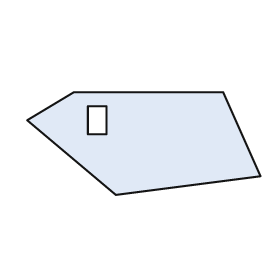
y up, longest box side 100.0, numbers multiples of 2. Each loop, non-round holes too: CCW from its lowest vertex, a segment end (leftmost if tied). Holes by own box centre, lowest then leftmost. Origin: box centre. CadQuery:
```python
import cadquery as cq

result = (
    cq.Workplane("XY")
    .moveTo(-12.0, -22.0)
    .lineTo(50.0, -14.0)
    .lineTo(34.0, 22.0)
    .lineTo(-30.0, 22.0)
    .lineTo(-50.0, 10.0)
    .close()
    .moveTo(-24.0, 4.0)
    .lineTo(-16.0, 4.0)
    .lineTo(-16.0, 16.0)
    .lineTo(-24.0, 16.0)
    .close()
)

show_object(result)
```